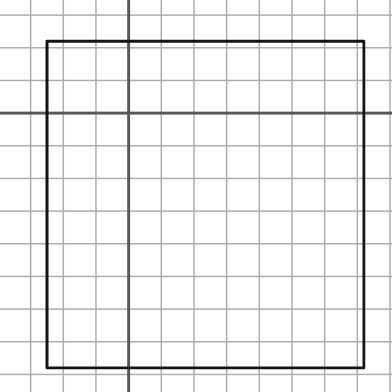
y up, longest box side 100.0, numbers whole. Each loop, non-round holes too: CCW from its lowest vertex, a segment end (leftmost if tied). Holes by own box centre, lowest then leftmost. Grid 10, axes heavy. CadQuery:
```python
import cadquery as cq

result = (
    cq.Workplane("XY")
    .moveTo(-25.0, -78.0)
    .lineTo(72.0, -78.0)
    .lineTo(72.0, 22.0)
    .lineTo(-25.0, 22.0)
    .close()
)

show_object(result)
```